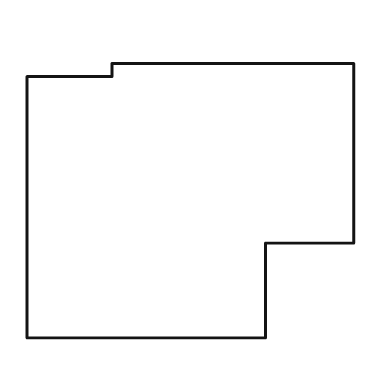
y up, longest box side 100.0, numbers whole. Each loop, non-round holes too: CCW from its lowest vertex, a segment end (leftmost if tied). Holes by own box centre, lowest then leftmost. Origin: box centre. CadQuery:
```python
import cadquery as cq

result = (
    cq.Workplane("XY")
    .moveTo(-50.0, -42.0)
    .lineTo(23.0, -42.0)
    .lineTo(23.0, -13.0)
    .lineTo(50.0, -13.0)
    .lineTo(50.0, 42.0)
    .lineTo(-24.0, 42.0)
    .lineTo(-24.0, 38.0)
    .lineTo(-50.0, 38.0)
    .close()
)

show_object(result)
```